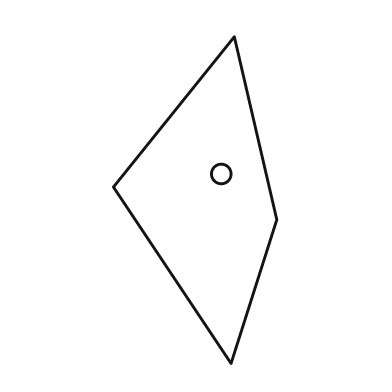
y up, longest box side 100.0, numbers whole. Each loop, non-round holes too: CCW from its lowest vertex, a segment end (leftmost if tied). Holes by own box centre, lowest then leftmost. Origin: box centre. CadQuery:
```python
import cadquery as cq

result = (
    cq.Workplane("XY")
    .moveTo(11.0, -50.0)
    .lineTo(25.0, -6.0)
    .lineTo(12.0, 50.0)
    .lineTo(-25.0, 4.0)
    .close()
    .moveTo(8.0, 8.0)
    .circle(3.0)
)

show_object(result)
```